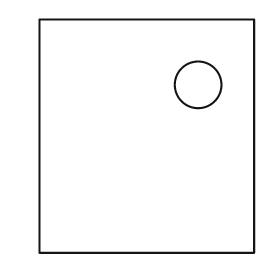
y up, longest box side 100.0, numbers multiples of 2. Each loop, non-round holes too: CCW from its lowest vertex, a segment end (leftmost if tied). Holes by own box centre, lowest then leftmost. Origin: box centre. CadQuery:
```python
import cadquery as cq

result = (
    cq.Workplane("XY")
    .moveTo(-46.0, -50.0)
    .lineTo(46.0, -50.0)
    .lineTo(46.0, 50.0)
    .lineTo(-46.0, 50.0)
    .close()
    .moveTo(22.0, 22.0)
    .circle(10.0)
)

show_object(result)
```